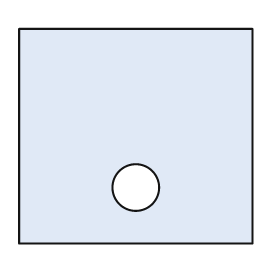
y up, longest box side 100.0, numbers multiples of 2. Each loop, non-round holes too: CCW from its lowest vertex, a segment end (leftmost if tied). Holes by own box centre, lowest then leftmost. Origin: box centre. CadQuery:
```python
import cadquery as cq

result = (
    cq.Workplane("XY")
    .moveTo(-50.0, -46.0)
    .lineTo(50.0, -46.0)
    .lineTo(50.0, 46.0)
    .lineTo(-50.0, 46.0)
    .close()
    .moveTo(0.0, -22.0)
    .circle(10.0)
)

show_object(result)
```